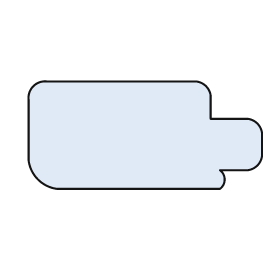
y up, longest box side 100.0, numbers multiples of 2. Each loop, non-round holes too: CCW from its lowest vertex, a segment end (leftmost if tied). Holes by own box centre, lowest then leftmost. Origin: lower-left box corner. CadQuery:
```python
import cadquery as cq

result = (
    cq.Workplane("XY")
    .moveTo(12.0, 0.0)
    .lineTo(82.0, 0.0)
    .threePointArc((84.0, 4.0), (82.0, 8.0))
    .lineTo(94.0, 8.0)
    .threePointArc((98.0, 10.0), (100.0, 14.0))
    .lineTo(100.0, 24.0)
    .threePointArc((98.0, 28.0), (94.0, 30.0))
    .lineTo(78.0, 30.0)
    .lineTo(78.0, 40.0)
    .threePointArc((76.0, 44.0), (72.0, 46.0))
    .lineTo(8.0, 46.0)
    .threePointArc((2.0, 44.0), (0.0, 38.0))
    .lineTo(0.0, 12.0)
    .threePointArc((4.0, 4.0), (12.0, 0.0))
    .close()
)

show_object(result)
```